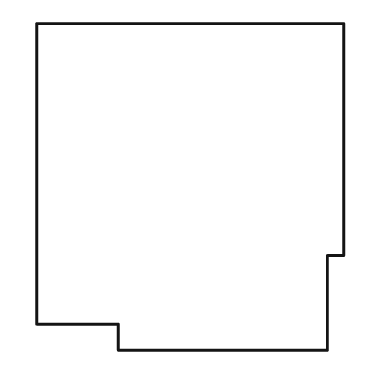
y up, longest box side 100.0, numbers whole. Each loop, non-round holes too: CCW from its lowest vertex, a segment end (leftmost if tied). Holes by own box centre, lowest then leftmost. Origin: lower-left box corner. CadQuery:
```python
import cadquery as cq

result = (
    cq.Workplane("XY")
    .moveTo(25.0, 0.0)
    .lineTo(89.0, 0.0)
    .lineTo(89.0, 29.0)
    .lineTo(94.0, 29.0)
    .lineTo(94.0, 100.0)
    .lineTo(0.0, 100.0)
    .lineTo(0.0, 8.0)
    .lineTo(25.0, 8.0)
    .close()
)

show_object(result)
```